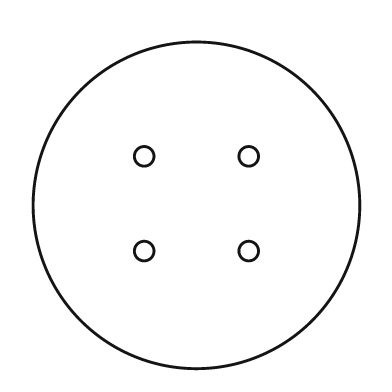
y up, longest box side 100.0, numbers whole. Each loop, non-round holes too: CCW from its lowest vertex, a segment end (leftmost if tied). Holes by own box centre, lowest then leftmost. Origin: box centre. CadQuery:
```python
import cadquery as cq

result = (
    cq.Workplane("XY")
    .moveTo(0.0, 0.0)
    .circle(50.0)
    .moveTo(-16.0, -14.0)
    .circle(3.0)
    .moveTo(16.0, -14.0)
    .circle(3.0)
    .moveTo(-16.0, 15.0)
    .circle(3.0)
    .moveTo(16.0, 15.0)
    .circle(3.0)
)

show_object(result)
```